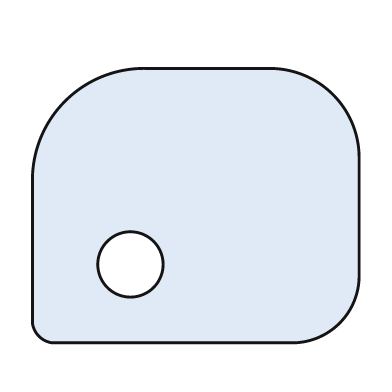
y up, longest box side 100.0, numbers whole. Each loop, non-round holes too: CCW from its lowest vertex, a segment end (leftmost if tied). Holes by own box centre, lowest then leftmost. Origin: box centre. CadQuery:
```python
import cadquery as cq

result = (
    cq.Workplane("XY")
    .moveTo(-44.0, -42.0)
    .lineTo(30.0, -42.0)
    .threePointArc((44.0, -36.0), (50.0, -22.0))
    .lineTo(50.0, 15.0)
    .threePointArc((42.0, 34.0), (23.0, 42.0))
    .lineTo(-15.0, 42.0)
    .threePointArc((-40.0, 32.0), (-50.0, 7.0))
    .lineTo(-50.0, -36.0)
    .threePointArc((-48.0, -40.0), (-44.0, -42.0))
    .close()
    .moveTo(-20.0, -18.0)
    .circle(10.0)
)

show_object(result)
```